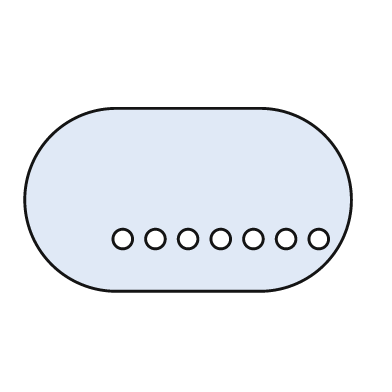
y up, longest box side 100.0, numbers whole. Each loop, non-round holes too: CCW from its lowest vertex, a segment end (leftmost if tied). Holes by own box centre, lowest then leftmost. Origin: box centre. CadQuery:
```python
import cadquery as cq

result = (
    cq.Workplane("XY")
    .moveTo(-22.0, -28.0)
    .lineTo(22.0, -28.0)
    .threePointArc((50.0, 0.0), (22.0, 28.0))
    .lineTo(-22.0, 28.0)
    .threePointArc((-50.0, 0.0), (-22.0, -28.0))
    .close()
    .moveTo(-20.0, -12.0)
    .circle(3.0)
    .moveTo(-10.0, -12.0)
    .circle(3.0)
    .moveTo(0.0, -12.0)
    .circle(3.0)
    .moveTo(10.0, -12.0)
    .circle(3.0)
    .moveTo(20.0, -12.0)
    .circle(3.0)
    .moveTo(30.0, -12.0)
    .circle(3.0)
    .moveTo(40.0, -12.0)
    .circle(3.0)
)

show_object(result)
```